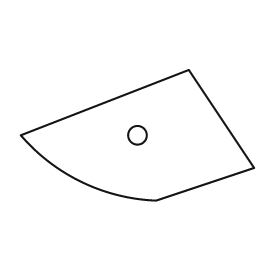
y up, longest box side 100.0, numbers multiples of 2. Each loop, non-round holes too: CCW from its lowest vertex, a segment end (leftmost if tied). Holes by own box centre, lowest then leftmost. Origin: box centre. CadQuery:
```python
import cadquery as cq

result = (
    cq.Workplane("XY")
    .moveTo(8.0, -28.0)
    .lineTo(50.0, -14.0)
    .lineTo(22.0, 28.0)
    .lineTo(-50.0, 0.0)
    .threePointArc((-24.0, -20.0), (8.0, -28.0))
    .close()
    .moveTo(0.0, 0.0)
    .circle(4.0)
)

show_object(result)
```